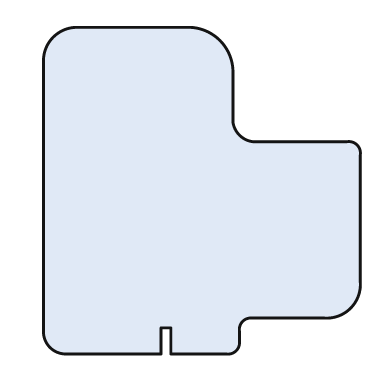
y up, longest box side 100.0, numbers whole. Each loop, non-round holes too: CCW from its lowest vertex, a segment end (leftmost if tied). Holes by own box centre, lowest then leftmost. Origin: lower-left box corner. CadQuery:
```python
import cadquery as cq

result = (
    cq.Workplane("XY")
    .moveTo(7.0, 0.0)
    .lineTo(36.0, 0.0)
    .lineTo(36.0, 8.0)
    .lineTo(39.0, 8.0)
    .lineTo(39.0, 0.0)
    .lineTo(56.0, 0.0)
    .threePointArc((59.0, 1.0), (60.0, 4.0))
    .lineTo(60.0, 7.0)
    .threePointArc((61.0, 10.0), (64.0, 11.0))
    .lineTo(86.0, 11.0)
    .threePointArc((94.0, 14.0), (97.0, 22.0))
    .lineTo(97.0, 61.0)
    .threePointArc((96.0, 64.0), (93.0, 65.0))
    .lineTo(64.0, 65.0)
    .threePointArc((60.0, 67.0), (58.0, 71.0))
    .lineTo(58.0, 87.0)
    .threePointArc((54.0, 96.0), (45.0, 100.0))
    .lineTo(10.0, 100.0)
    .threePointArc((3.0, 97.0), (0.0, 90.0))
    .lineTo(0.0, 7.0)
    .threePointArc((2.0, 2.0), (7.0, 0.0))
    .close()
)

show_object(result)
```